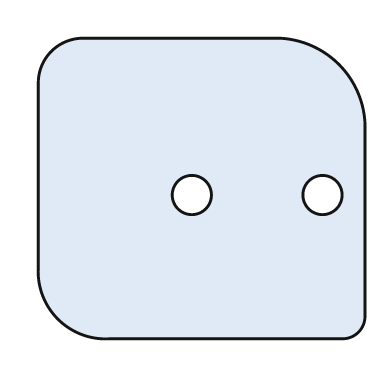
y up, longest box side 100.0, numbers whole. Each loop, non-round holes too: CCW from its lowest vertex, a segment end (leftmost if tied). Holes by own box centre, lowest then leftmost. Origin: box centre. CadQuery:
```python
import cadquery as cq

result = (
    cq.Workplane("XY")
    .moveTo(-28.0, -46.0)
    .lineTo(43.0, -46.0)
    .threePointArc((48.0, -44.0), (50.0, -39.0))
    .lineTo(50.0, 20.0)
    .threePointArc((42.0, 38.0), (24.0, 46.0))
    .lineTo(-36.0, 46.0)
    .threePointArc((-46.0, 42.0), (-50.0, 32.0))
    .lineTo(-50.0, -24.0)
    .threePointArc((-44.0, -40.0), (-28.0, -46.0))
    .close()
    .moveTo(-3.0, -2.0)
    .circle(6.0)
    .moveTo(37.0, -2.0)
    .circle(6.0)
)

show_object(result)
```